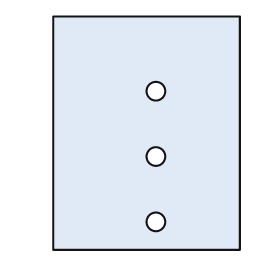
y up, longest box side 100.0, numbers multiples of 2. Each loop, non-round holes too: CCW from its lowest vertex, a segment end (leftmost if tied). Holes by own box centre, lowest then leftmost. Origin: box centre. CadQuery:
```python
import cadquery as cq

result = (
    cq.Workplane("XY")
    .moveTo(-40.0, -50.0)
    .lineTo(40.0, -50.0)
    .lineTo(40.0, 50.0)
    .lineTo(-40.0, 50.0)
    .close()
    .moveTo(4.0, -38.0)
    .circle(4.0)
    .moveTo(4.0, -10.0)
    .circle(4.0)
    .moveTo(4.0, 18.0)
    .circle(4.0)
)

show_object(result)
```